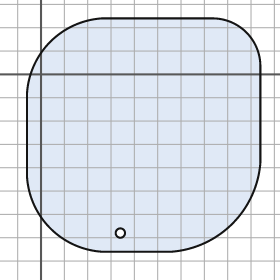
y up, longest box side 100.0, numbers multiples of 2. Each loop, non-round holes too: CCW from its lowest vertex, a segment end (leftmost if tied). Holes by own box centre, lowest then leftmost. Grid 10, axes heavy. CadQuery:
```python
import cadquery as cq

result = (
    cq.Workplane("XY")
    .moveTo(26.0, -76.0)
    .lineTo(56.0, -76.0)
    .threePointArc((82.0, -64.0), (94.0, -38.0))
    .lineTo(94.0, 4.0)
    .threePointArc((88.0, 18.0), (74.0, 24.0))
    .lineTo(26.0, 24.0)
    .threePointArc((4.0, 14.0), (-6.0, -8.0))
    .lineTo(-6.0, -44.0)
    .threePointArc((4.0, -66.0), (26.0, -76.0))
    .close()
    .moveTo(34.0, -68.0)
    .circle(2.0)
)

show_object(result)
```